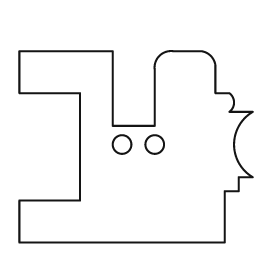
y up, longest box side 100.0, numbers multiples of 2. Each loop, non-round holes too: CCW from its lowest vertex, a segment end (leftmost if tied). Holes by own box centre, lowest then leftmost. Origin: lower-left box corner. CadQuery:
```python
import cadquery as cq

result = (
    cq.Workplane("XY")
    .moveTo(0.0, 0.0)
    .lineTo(88.0, 0.0)
    .lineTo(88.0, 22.0)
    .lineTo(94.0, 22.0)
    .lineTo(94.0, 28.0)
    .lineTo(100.0, 28.0)
    .threePointArc((92.0, 42.0), (100.0, 56.0))
    .lineTo(90.0, 56.0)
    .threePointArc((92.0, 60.0), (90.0, 64.0))
    .lineTo(84.0, 64.0)
    .lineTo(84.0, 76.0)
    .threePointArc((82.0, 80.0), (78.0, 82.0))
    .lineTo(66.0, 82.0)
    .threePointArc((60.0, 80.0), (58.0, 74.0))
    .lineTo(58.0, 50.0)
    .lineTo(40.0, 50.0)
    .lineTo(40.0, 82.0)
    .lineTo(0.0, 82.0)
    .lineTo(0.0, 64.0)
    .lineTo(26.0, 64.0)
    .lineTo(26.0, 18.0)
    .lineTo(0.0, 18.0)
    .close()
    .moveTo(44.0, 42.0)
    .circle(4.0)
    .moveTo(58.0, 42.0)
    .circle(4.0)
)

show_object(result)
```